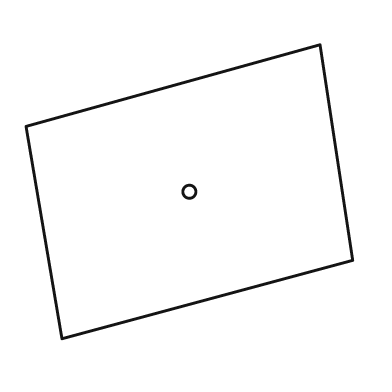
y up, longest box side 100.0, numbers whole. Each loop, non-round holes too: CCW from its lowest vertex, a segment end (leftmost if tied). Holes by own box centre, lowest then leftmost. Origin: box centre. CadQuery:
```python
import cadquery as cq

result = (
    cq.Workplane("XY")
    .moveTo(-39.0, -45.0)
    .lineTo(50.0, -21.0)
    .lineTo(40.0, 45.0)
    .lineTo(-50.0, 20.0)
    .close()
    .moveTo(0.0, 0.0)
    .circle(2.0)
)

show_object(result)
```